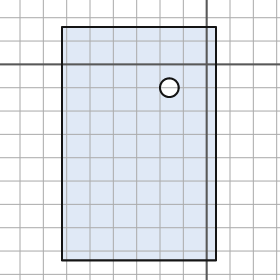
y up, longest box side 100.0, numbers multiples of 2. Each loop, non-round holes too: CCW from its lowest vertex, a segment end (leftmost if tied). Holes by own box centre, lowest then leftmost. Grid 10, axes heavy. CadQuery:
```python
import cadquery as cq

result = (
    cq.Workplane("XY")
    .moveTo(-62.0, -84.0)
    .lineTo(4.0, -84.0)
    .lineTo(4.0, 16.0)
    .lineTo(-62.0, 16.0)
    .close()
    .moveTo(-16.0, -10.0)
    .circle(4.0)
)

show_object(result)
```